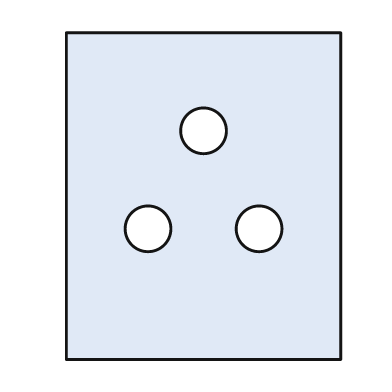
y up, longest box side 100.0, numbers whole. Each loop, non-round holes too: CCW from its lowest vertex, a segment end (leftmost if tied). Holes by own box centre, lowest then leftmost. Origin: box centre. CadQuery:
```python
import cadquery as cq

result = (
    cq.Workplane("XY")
    .moveTo(-42.0, -50.0)
    .lineTo(42.0, -50.0)
    .lineTo(42.0, 50.0)
    .lineTo(-42.0, 50.0)
    .close()
    .moveTo(-17.0, -10.0)
    .circle(7.0)
    .moveTo(17.0, -10.0)
    .circle(7.0)
    .moveTo(0.0, 20.0)
    .circle(7.0)
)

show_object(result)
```